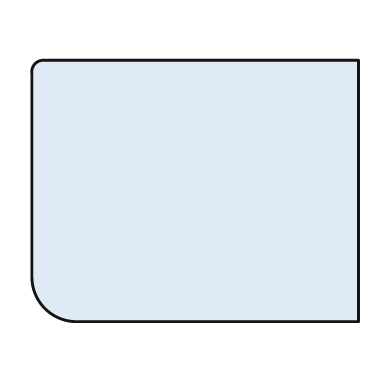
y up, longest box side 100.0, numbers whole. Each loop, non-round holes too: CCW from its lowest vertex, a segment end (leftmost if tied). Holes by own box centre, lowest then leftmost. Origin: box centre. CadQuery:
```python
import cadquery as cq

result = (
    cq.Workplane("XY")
    .moveTo(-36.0, -40.0)
    .lineTo(50.0, -40.0)
    .lineTo(50.0, 40.0)
    .lineTo(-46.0, 40.0)
    .threePointArc((-49.0, 39.0), (-50.0, 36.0))
    .lineTo(-50.0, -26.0)
    .threePointArc((-46.0, -36.0), (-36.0, -40.0))
    .close()
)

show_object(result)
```